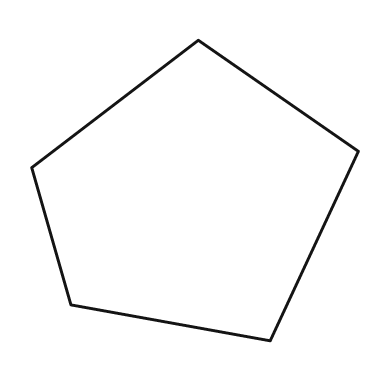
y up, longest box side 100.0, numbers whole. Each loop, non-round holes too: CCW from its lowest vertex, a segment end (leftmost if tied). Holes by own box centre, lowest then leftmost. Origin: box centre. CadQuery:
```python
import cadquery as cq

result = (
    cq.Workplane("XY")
    .moveTo(23.0, -46.0)
    .lineTo(50.0, 12.0)
    .lineTo(1.0, 46.0)
    .lineTo(-50.0, 7.0)
    .lineTo(-38.0, -35.0)
    .close()
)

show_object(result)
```